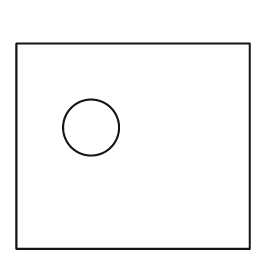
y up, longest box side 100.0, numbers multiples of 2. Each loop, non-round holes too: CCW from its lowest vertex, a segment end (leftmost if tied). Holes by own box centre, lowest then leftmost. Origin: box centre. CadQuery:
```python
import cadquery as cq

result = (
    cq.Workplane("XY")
    .moveTo(-50.0, -44.0)
    .lineTo(50.0, -44.0)
    .lineTo(50.0, 44.0)
    .lineTo(-50.0, 44.0)
    .close()
    .moveTo(-18.0, 8.0)
    .circle(12.0)
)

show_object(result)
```